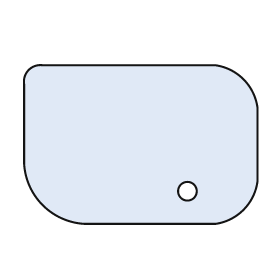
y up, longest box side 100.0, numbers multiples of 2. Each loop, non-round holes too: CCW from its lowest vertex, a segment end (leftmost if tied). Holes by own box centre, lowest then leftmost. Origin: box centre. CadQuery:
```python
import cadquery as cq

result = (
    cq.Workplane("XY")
    .moveTo(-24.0, -34.0)
    .lineTo(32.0, -34.0)
    .threePointArc((44.0, -28.0), (50.0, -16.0))
    .lineTo(50.0, 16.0)
    .threePointArc((44.0, 28.0), (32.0, 34.0))
    .lineTo(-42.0, 34.0)
    .threePointArc((-48.0, 32.0), (-50.0, 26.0))
    .lineTo(-50.0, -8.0)
    .threePointArc((-42.0, -26.0), (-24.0, -34.0))
    .close()
    .moveTo(20.0, -20.0)
    .circle(4.0)
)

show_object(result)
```